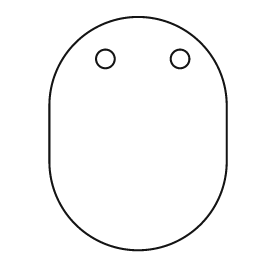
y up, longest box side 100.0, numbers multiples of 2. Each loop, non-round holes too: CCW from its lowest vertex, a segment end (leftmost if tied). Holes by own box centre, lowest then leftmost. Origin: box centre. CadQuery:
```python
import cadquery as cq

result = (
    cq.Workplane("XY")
    .moveTo(-38.0, -12.0)
    .threePointArc((0.0, -50.0), (38.0, -12.0))
    .lineTo(38.0, 12.0)
    .threePointArc((0.0, 50.0), (-38.0, 12.0))
    .close()
    .moveTo(-14.0, 32.0)
    .circle(4.0)
    .moveTo(18.0, 32.0)
    .circle(4.0)
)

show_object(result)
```